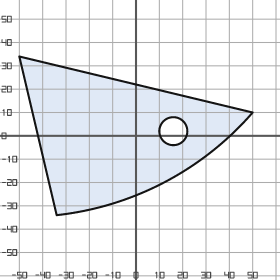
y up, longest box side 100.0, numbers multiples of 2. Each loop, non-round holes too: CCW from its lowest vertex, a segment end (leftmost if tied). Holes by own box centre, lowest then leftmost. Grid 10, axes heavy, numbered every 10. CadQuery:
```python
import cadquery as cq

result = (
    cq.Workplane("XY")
    .moveTo(-34.0, -34.0)
    .threePointArc((12.0, -20.0), (50.0, 10.0))
    .lineTo(-50.0, 34.0)
    .close()
    .moveTo(16.0, 2.0)
    .circle(6.0)
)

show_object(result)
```